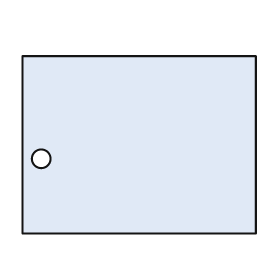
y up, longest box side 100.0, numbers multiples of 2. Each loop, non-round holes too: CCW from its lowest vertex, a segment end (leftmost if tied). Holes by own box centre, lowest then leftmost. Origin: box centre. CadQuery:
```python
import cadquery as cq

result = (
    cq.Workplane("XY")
    .moveTo(-50.0, -38.0)
    .lineTo(50.0, -38.0)
    .lineTo(50.0, 38.0)
    .lineTo(-50.0, 38.0)
    .close()
    .moveTo(-42.0, -6.0)
    .circle(4.0)
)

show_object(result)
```